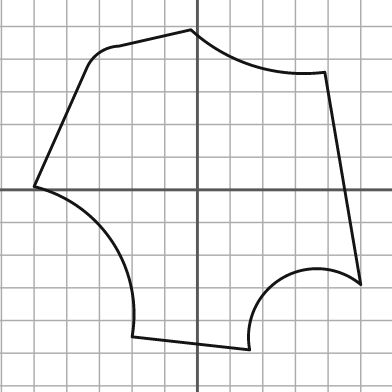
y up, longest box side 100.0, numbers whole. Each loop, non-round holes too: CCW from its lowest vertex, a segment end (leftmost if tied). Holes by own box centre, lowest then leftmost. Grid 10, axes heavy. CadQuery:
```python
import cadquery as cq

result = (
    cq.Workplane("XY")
    .moveTo(16.0, -49.0)
    .threePointArc((26.0, -27.0), (50.0, -29.0))
    .lineTo(39.0, 36.0)
    .threePointArc((17.0, 38.0), (-2.0, 49.0))
    .lineTo(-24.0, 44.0)
    .threePointArc((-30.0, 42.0), (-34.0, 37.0))
    .lineTo(-50.0, 1.0)
    .threePointArc((-26.0, -16.0), (-20.0, -45.0))
    .close()
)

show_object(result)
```